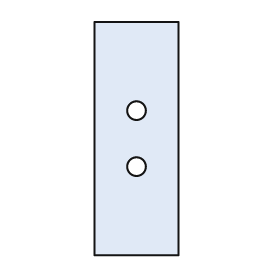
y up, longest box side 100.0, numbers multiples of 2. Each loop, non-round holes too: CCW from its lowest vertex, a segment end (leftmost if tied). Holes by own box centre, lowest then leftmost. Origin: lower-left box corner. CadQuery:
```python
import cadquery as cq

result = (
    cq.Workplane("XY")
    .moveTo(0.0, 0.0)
    .lineTo(36.0, 0.0)
    .lineTo(36.0, 100.0)
    .lineTo(0.0, 100.0)
    .close()
    .moveTo(18.0, 38.0)
    .circle(4.0)
    .moveTo(18.0, 62.0)
    .circle(4.0)
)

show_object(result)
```